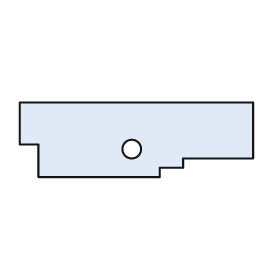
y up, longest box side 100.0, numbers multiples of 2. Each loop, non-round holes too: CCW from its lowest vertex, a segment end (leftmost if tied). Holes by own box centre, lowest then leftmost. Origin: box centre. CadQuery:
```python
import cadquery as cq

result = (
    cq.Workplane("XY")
    .moveTo(-42.0, -16.0)
    .lineTo(10.0, -16.0)
    .lineTo(10.0, -12.0)
    .lineTo(20.0, -12.0)
    .lineTo(20.0, -8.0)
    .lineTo(50.0, -8.0)
    .lineTo(50.0, 16.0)
    .lineTo(-50.0, 16.0)
    .lineTo(-50.0, -2.0)
    .lineTo(-42.0, -2.0)
    .close()
    .moveTo(-2.0, -4.0)
    .circle(4.0)
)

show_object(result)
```